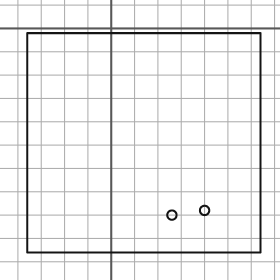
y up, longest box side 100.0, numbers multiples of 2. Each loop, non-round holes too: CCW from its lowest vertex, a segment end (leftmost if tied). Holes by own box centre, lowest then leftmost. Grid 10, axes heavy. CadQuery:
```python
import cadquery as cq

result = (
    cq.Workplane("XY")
    .moveTo(-36.0, -96.0)
    .lineTo(64.0, -96.0)
    .lineTo(64.0, -2.0)
    .lineTo(-36.0, -2.0)
    .close()
    .moveTo(26.0, -80.0)
    .circle(2.0)
    .moveTo(40.0, -78.0)
    .circle(2.0)
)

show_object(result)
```